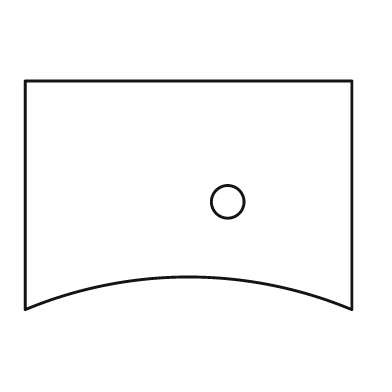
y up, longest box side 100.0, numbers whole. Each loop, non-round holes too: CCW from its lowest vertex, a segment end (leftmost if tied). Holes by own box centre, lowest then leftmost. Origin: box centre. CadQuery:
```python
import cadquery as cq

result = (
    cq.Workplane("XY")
    .moveTo(-50.0, -35.0)
    .threePointArc((0.0, -25.0), (50.0, -35.0))
    .lineTo(50.0, 35.0)
    .lineTo(-50.0, 35.0)
    .close()
    .moveTo(12.0, -2.0)
    .circle(5.0)
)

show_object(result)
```